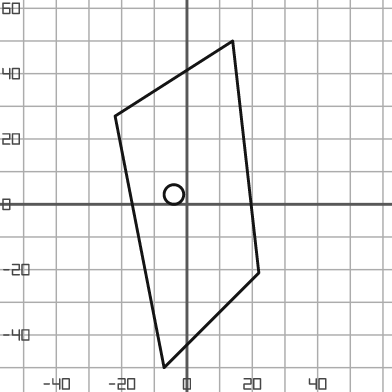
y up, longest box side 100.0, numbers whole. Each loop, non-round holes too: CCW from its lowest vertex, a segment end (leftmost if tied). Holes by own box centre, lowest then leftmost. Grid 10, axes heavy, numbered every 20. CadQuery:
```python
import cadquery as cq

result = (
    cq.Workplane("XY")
    .moveTo(-7.0, -50.0)
    .lineTo(22.0, -21.0)
    .lineTo(14.0, 50.0)
    .lineTo(-22.0, 27.0)
    .close()
    .moveTo(-4.0, 3.0)
    .circle(3.0)
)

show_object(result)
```